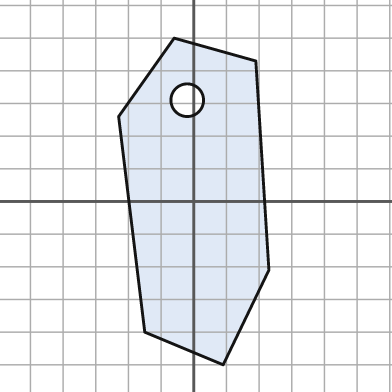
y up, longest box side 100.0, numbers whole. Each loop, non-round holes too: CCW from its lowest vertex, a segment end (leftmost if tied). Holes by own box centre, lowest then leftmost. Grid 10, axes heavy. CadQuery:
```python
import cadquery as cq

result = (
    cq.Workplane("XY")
    .moveTo(9.0, -50.0)
    .lineTo(23.0, -21.0)
    .lineTo(19.0, 43.0)
    .lineTo(-6.0, 50.0)
    .lineTo(-23.0, 26.0)
    .lineTo(-15.0, -40.0)
    .close()
    .moveTo(-2.0, 31.0)
    .circle(5.0)
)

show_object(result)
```